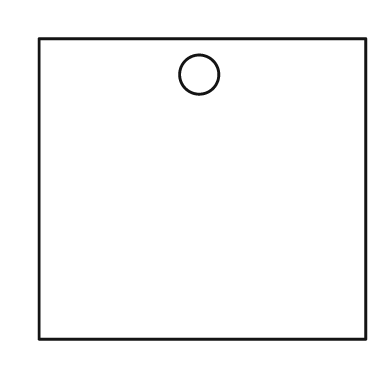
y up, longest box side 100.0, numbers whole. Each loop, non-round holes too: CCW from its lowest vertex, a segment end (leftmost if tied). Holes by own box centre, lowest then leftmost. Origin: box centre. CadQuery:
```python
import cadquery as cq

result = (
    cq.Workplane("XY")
    .moveTo(-50.0, -46.0)
    .lineTo(50.0, -46.0)
    .lineTo(50.0, 46.0)
    .lineTo(-50.0, 46.0)
    .close()
    .moveTo(-1.0, 35.0)
    .circle(6.0)
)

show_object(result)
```